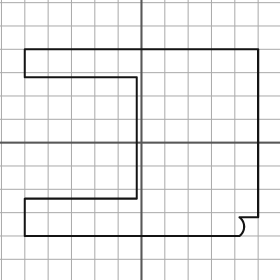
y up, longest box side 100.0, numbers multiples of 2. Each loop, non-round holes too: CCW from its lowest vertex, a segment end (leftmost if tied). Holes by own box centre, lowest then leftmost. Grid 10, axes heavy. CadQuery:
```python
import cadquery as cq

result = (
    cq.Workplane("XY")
    .moveTo(-50.0, -40.0)
    .lineTo(42.0, -40.0)
    .threePointArc((44.0, -36.0), (42.0, -32.0))
    .lineTo(50.0, -32.0)
    .lineTo(50.0, 40.0)
    .lineTo(-50.0, 40.0)
    .lineTo(-50.0, 28.0)
    .lineTo(-2.0, 28.0)
    .lineTo(-2.0, -24.0)
    .lineTo(-50.0, -24.0)
    .close()
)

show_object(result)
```